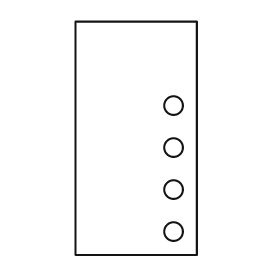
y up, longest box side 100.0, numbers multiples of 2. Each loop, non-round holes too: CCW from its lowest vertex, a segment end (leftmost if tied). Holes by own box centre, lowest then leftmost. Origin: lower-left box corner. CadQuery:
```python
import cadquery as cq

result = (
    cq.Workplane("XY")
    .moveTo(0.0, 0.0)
    .lineTo(52.0, 0.0)
    .lineTo(52.0, 100.0)
    .lineTo(0.0, 100.0)
    .close()
    .moveTo(42.0, 10.0)
    .circle(4.0)
    .moveTo(42.0, 28.0)
    .circle(4.0)
    .moveTo(42.0, 46.0)
    .circle(4.0)
    .moveTo(42.0, 64.0)
    .circle(4.0)
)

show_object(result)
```